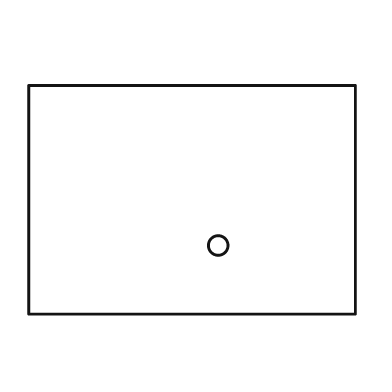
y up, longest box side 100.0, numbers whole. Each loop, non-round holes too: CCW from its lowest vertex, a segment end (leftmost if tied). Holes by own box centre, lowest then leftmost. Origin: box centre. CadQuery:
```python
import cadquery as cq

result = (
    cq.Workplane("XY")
    .moveTo(-50.0, -35.0)
    .lineTo(50.0, -35.0)
    .lineTo(50.0, 35.0)
    .lineTo(-50.0, 35.0)
    .close()
    .moveTo(8.0, -14.0)
    .circle(3.0)
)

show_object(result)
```